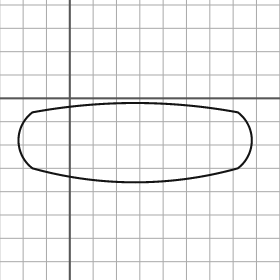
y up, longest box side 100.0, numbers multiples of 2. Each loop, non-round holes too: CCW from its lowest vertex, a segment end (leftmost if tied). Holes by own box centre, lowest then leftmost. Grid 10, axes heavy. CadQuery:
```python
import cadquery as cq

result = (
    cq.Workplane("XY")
    .moveTo(-16.0, -30.0)
    .threePointArc((28.0, -36.0), (72.0, -30.0))
    .threePointArc((78.0, -18.0), (72.0, -6.0))
    .threePointArc((28.0, -2.0), (-16.0, -6.0))
    .threePointArc((-22.0, -18.0), (-16.0, -30.0))
    .close()
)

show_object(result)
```